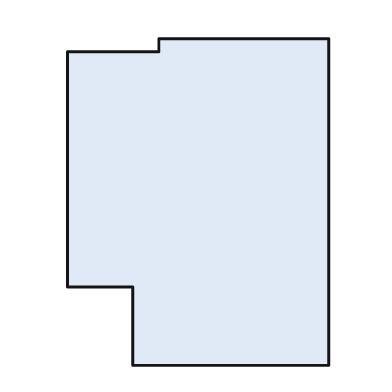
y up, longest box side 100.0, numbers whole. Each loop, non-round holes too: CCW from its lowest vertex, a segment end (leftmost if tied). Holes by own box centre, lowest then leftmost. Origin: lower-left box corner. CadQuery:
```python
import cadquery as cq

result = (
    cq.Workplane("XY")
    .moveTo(20.0, 0.0)
    .lineTo(80.0, 0.0)
    .lineTo(80.0, 100.0)
    .lineTo(28.0, 100.0)
    .lineTo(28.0, 96.0)
    .lineTo(0.0, 96.0)
    .lineTo(0.0, 24.0)
    .lineTo(20.0, 24.0)
    .close()
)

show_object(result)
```